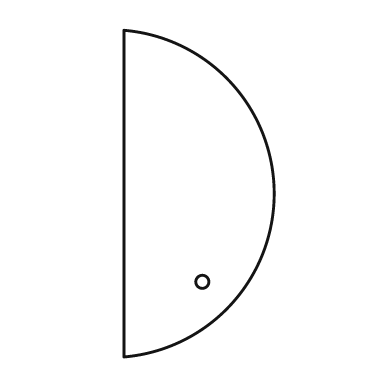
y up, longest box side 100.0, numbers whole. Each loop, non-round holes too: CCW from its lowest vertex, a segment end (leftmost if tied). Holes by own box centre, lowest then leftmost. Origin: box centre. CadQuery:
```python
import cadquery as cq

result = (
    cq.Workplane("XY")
    .moveTo(-23.0, -50.0)
    .threePointArc((23.0, 0.0), (-23.0, 50.0))
    .close()
    .moveTo(1.0, -27.0)
    .circle(2.0)
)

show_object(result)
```